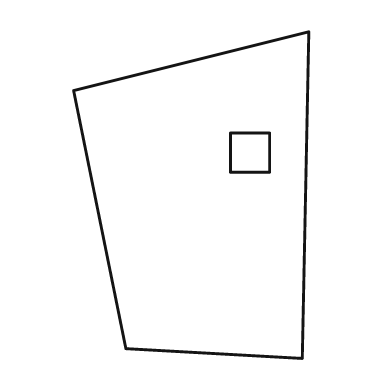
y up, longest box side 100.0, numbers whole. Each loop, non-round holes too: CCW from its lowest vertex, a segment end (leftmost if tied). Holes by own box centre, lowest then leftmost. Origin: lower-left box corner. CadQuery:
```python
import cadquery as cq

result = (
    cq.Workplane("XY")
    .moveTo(70.0, 0.0)
    .lineTo(72.0, 100.0)
    .lineTo(0.0, 82.0)
    .lineTo(16.0, 3.0)
    .close()
    .moveTo(48.0, 57.0)
    .lineTo(60.0, 57.0)
    .lineTo(60.0, 69.0)
    .lineTo(48.0, 69.0)
    .close()
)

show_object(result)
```